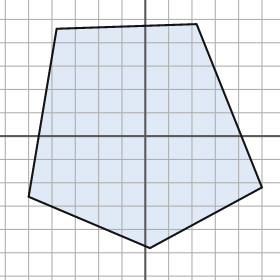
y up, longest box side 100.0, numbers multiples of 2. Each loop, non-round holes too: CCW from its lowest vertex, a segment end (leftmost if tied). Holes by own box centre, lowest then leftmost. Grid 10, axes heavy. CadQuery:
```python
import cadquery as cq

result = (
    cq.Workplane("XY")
    .moveTo(2.0, -48.0)
    .lineTo(50.0, -22.0)
    .lineTo(22.0, 48.0)
    .lineTo(-38.0, 46.0)
    .lineTo(-50.0, -26.0)
    .close()
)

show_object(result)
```